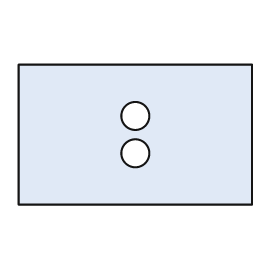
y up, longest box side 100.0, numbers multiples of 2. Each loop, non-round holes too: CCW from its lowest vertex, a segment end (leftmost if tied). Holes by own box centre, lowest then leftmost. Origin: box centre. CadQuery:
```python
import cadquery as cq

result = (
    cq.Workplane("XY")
    .moveTo(-50.0, -30.0)
    .lineTo(50.0, -30.0)
    .lineTo(50.0, 30.0)
    .lineTo(-50.0, 30.0)
    .close()
    .moveTo(0.0, -8.0)
    .circle(6.0)
    .moveTo(0.0, 8.0)
    .circle(6.0)
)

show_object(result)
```